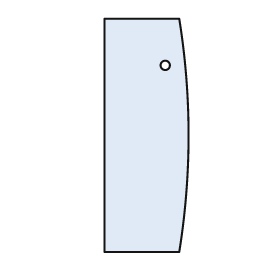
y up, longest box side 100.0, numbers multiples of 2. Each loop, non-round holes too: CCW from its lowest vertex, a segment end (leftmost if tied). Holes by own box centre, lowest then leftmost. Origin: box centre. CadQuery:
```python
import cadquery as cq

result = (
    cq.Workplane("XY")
    .moveTo(-18.0, -50.0)
    .lineTo(14.0, -50.0)
    .threePointArc((18.0, 0.0), (14.0, 50.0))
    .lineTo(-18.0, 50.0)
    .close()
    .moveTo(8.0, 30.0)
    .circle(2.0)
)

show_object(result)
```